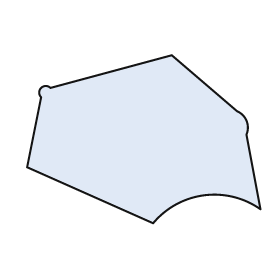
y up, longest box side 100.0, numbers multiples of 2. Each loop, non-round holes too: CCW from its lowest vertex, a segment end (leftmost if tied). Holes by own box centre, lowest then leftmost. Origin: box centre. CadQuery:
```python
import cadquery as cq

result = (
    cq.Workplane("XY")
    .moveTo(4.0, -36.0)
    .threePointArc((26.0, -24.0), (50.0, -30.0))
    .lineTo(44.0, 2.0)
    .threePointArc((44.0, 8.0), (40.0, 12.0))
    .lineTo(12.0, 36.0)
    .lineTo(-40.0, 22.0)
    .threePointArc((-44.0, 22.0), (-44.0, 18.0))
    .lineTo(-50.0, -12.0)
    .close()
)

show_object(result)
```